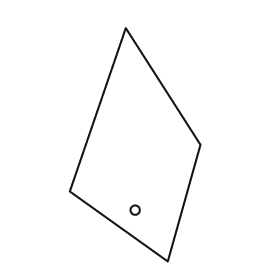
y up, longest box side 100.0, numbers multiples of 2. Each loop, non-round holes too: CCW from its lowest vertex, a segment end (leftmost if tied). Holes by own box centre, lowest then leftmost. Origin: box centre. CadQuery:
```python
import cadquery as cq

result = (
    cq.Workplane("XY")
    .moveTo(14.0, -50.0)
    .lineTo(28.0, 0.0)
    .lineTo(-4.0, 50.0)
    .lineTo(-28.0, -20.0)
    .close()
    .moveTo(0.0, -28.0)
    .circle(2.0)
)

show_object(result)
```